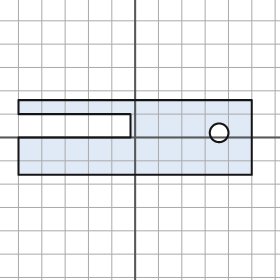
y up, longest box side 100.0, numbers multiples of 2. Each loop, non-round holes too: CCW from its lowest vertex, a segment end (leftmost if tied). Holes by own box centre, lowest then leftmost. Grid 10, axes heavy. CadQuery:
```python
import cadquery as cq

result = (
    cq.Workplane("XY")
    .moveTo(-50.0, -16.0)
    .lineTo(50.0, -16.0)
    .lineTo(50.0, 16.0)
    .lineTo(-50.0, 16.0)
    .lineTo(-50.0, 10.0)
    .lineTo(-2.0, 10.0)
    .lineTo(-2.0, 0.0)
    .lineTo(-50.0, 0.0)
    .close()
    .moveTo(36.0, 2.0)
    .circle(4.0)
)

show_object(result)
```